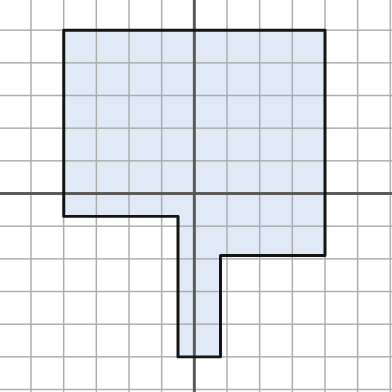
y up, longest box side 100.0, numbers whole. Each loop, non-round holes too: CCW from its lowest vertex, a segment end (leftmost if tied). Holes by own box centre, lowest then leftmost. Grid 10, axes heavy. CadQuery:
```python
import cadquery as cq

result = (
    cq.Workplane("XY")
    .moveTo(-5.0, -50.0)
    .lineTo(8.0, -50.0)
    .lineTo(8.0, -19.0)
    .lineTo(40.0, -19.0)
    .lineTo(40.0, 50.0)
    .lineTo(-40.0, 50.0)
    .lineTo(-40.0, -7.0)
    .lineTo(-5.0, -7.0)
    .close()
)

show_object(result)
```